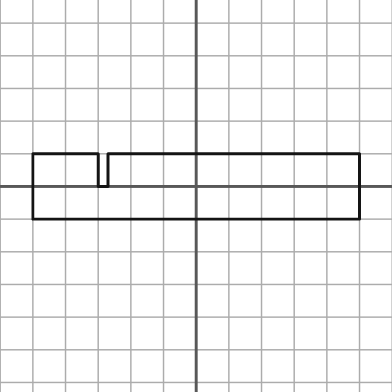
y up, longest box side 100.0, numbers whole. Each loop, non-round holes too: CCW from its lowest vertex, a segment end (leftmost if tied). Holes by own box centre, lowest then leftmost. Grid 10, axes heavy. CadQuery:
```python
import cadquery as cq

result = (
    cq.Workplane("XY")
    .moveTo(-50.0, -10.0)
    .lineTo(50.0, -10.0)
    .lineTo(50.0, 10.0)
    .lineTo(-27.0, 10.0)
    .lineTo(-27.0, 0.0)
    .lineTo(-30.0, 0.0)
    .lineTo(-30.0, 10.0)
    .lineTo(-50.0, 10.0)
    .close()
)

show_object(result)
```